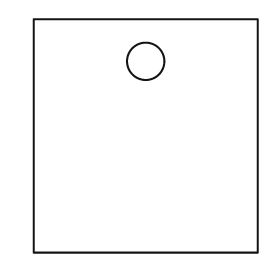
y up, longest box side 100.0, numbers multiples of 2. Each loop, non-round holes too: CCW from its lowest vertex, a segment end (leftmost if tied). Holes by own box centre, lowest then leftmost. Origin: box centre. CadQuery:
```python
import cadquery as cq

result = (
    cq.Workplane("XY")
    .moveTo(-48.0, -50.0)
    .lineTo(48.0, -50.0)
    .lineTo(48.0, 50.0)
    .lineTo(-48.0, 50.0)
    .close()
    .moveTo(0.0, 32.0)
    .circle(8.0)
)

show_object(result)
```